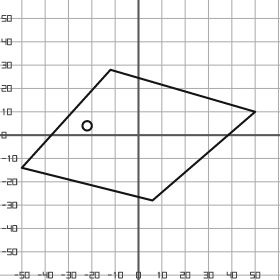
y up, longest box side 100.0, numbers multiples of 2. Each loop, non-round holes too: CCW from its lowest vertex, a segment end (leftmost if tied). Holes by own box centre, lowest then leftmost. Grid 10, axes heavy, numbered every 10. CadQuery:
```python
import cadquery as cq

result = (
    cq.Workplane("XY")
    .moveTo(6.0, -28.0)
    .lineTo(50.0, 10.0)
    .lineTo(-12.0, 28.0)
    .lineTo(-50.0, -14.0)
    .close()
    .moveTo(-22.0, 4.0)
    .circle(2.0)
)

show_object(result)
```